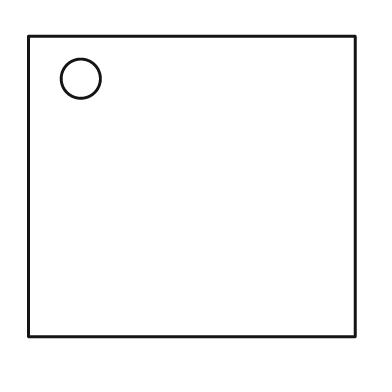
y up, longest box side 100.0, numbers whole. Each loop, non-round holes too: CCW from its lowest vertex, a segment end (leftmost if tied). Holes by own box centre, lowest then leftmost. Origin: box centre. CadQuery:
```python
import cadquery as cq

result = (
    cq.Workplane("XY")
    .moveTo(-50.0, -46.0)
    .lineTo(50.0, -46.0)
    .lineTo(50.0, 46.0)
    .lineTo(-50.0, 46.0)
    .close()
    .moveTo(-34.0, 33.0)
    .circle(6.0)
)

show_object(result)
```